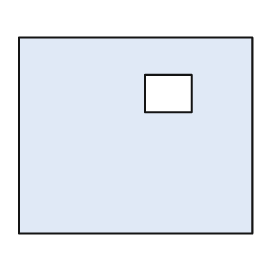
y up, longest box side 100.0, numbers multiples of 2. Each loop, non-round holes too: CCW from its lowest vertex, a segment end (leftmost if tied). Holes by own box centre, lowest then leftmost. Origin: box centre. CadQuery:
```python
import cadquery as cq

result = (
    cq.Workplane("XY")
    .moveTo(-50.0, -42.0)
    .lineTo(50.0, -42.0)
    .lineTo(50.0, 42.0)
    .lineTo(-50.0, 42.0)
    .close()
    .moveTo(4.0, 10.0)
    .lineTo(24.0, 10.0)
    .lineTo(24.0, 26.0)
    .lineTo(4.0, 26.0)
    .close()
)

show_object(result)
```